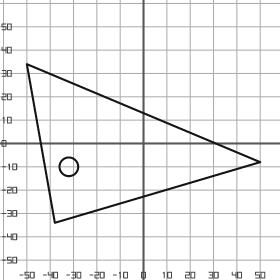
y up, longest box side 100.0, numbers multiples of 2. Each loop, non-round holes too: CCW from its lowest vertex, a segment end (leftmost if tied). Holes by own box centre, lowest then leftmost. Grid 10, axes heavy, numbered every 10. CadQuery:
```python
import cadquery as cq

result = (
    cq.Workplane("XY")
    .moveTo(-38.0, -34.0)
    .lineTo(50.0, -8.0)
    .lineTo(-50.0, 34.0)
    .close()
    .moveTo(-32.0, -10.0)
    .circle(4.0)
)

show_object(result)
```